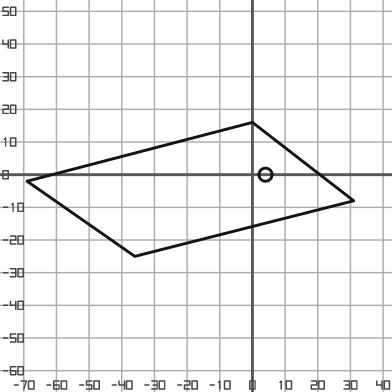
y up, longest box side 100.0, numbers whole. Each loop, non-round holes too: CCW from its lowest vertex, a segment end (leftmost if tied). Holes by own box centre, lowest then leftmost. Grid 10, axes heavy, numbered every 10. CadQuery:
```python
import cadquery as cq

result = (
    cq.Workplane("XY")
    .moveTo(-36.0, -25.0)
    .lineTo(31.0, -8.0)
    .lineTo(0.0, 16.0)
    .lineTo(-69.0, -2.0)
    .close()
    .moveTo(4.0, 0.0)
    .circle(2.0)
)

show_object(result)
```